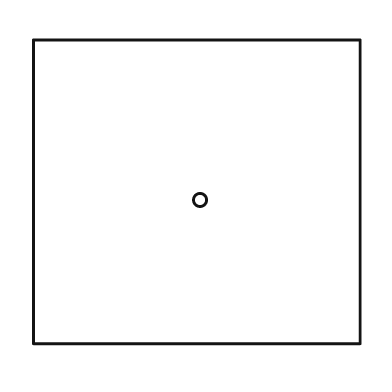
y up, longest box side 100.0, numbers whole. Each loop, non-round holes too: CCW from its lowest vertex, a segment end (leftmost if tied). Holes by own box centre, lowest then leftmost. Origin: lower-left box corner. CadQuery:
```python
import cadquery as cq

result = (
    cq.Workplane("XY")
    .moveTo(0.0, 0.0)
    .lineTo(100.0, 0.0)
    .lineTo(100.0, 93.0)
    .lineTo(0.0, 93.0)
    .close()
    .moveTo(51.0, 44.0)
    .circle(2.0)
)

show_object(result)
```